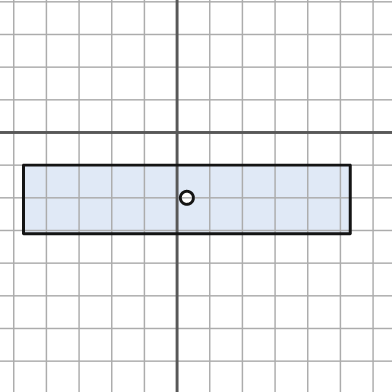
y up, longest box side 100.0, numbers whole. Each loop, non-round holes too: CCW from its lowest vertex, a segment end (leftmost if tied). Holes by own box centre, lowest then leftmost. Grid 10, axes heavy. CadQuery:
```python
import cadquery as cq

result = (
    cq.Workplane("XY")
    .moveTo(-47.0, -31.0)
    .lineTo(53.0, -31.0)
    .lineTo(53.0, -10.0)
    .lineTo(-47.0, -10.0)
    .close()
    .moveTo(3.0, -20.0)
    .circle(2.0)
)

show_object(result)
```